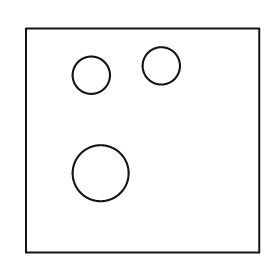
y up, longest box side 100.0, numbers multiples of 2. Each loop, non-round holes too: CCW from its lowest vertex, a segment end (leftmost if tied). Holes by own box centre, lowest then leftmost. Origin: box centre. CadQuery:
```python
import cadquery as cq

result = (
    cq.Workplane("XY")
    .moveTo(-50.0, -48.0)
    .lineTo(50.0, -48.0)
    .lineTo(50.0, 48.0)
    .lineTo(-50.0, 48.0)
    .close()
    .moveTo(-18.0, -14.0)
    .circle(12.0)
    .moveTo(-22.0, 28.0)
    .circle(8.0)
    .moveTo(8.0, 32.0)
    .circle(8.0)
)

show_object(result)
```